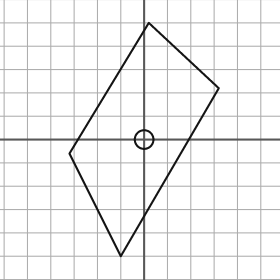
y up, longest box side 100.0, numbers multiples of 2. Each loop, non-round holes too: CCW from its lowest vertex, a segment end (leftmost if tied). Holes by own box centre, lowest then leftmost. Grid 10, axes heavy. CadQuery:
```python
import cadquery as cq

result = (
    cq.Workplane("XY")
    .moveTo(-10.0, -50.0)
    .lineTo(32.0, 22.0)
    .lineTo(2.0, 50.0)
    .lineTo(-32.0, -6.0)
    .close()
    .moveTo(0.0, 0.0)
    .circle(4.0)
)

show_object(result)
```